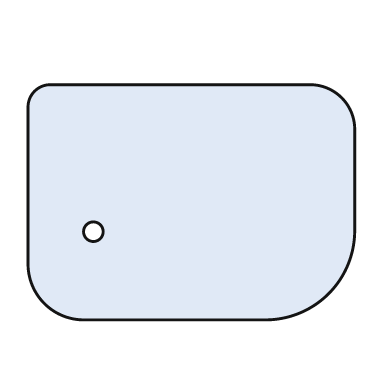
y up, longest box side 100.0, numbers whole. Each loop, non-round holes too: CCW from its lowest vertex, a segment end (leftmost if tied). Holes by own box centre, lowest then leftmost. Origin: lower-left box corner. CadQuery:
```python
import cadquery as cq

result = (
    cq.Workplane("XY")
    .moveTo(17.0, 0.0)
    .lineTo(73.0, 0.0)
    .threePointArc((92.0, 8.0), (100.0, 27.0))
    .lineTo(100.0, 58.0)
    .threePointArc((96.0, 68.0), (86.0, 72.0))
    .lineTo(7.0, 72.0)
    .threePointArc((2.0, 70.0), (0.0, 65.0))
    .lineTo(0.0, 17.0)
    .threePointArc((5.0, 5.0), (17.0, 0.0))
    .close()
    .moveTo(20.0, 27.0)
    .circle(3.0)
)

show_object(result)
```